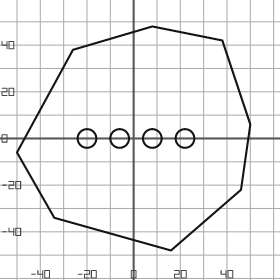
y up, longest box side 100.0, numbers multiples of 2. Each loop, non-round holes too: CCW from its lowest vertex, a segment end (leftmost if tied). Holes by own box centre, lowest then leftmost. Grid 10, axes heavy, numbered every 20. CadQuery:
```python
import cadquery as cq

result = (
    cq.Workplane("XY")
    .moveTo(16.0, -48.0)
    .lineTo(46.0, -22.0)
    .lineTo(50.0, 6.0)
    .lineTo(38.0, 42.0)
    .lineTo(8.0, 48.0)
    .lineTo(-26.0, 38.0)
    .lineTo(-50.0, -6.0)
    .lineTo(-34.0, -34.0)
    .close()
    .moveTo(-20.0, 0.0)
    .circle(4.0)
    .moveTo(-6.0, 0.0)
    .circle(4.0)
    .moveTo(8.0, 0.0)
    .circle(4.0)
    .moveTo(22.0, 0.0)
    .circle(4.0)
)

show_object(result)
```